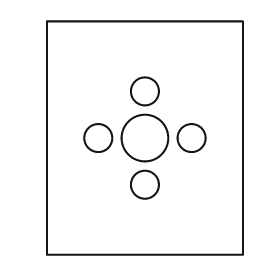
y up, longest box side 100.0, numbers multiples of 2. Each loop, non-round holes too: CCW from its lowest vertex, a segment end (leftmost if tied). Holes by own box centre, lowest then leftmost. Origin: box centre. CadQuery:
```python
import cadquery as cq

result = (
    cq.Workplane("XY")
    .moveTo(-42.0, -50.0)
    .lineTo(42.0, -50.0)
    .lineTo(42.0, 50.0)
    .lineTo(-42.0, 50.0)
    .close()
    .moveTo(0.0, -20.0)
    .circle(6.0)
    .moveTo(-20.0, 0.0)
    .circle(6.0)
    .moveTo(0.0, 0.0)
    .circle(10.0)
    .moveTo(20.0, 0.0)
    .circle(6.0)
    .moveTo(0.0, 20.0)
    .circle(6.0)
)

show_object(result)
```